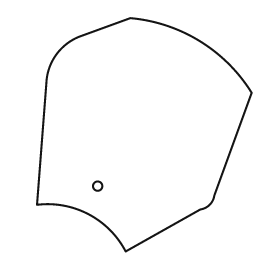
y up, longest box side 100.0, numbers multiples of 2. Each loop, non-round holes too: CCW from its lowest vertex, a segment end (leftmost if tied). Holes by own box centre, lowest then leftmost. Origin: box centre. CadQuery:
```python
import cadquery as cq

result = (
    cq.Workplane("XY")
    .moveTo(-8.0, -50.0)
    .lineTo(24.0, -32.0)
    .threePointArc((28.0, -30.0), (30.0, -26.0))
    .lineTo(46.0, 18.0)
    .threePointArc((24.0, 40.0), (-6.0, 50.0))
    .lineTo(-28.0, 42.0)
    .threePointArc((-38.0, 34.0), (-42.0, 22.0))
    .lineTo(-46.0, -30.0)
    .threePointArc((-24.0, -34.0), (-8.0, -50.0))
    .close()
    .moveTo(-20.0, -22.0)
    .circle(2.0)
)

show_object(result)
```